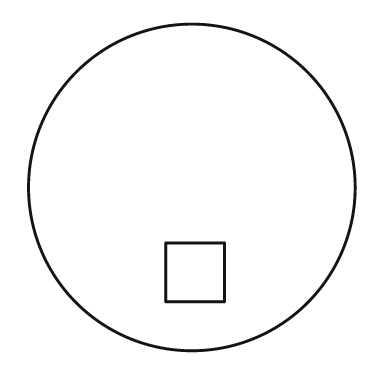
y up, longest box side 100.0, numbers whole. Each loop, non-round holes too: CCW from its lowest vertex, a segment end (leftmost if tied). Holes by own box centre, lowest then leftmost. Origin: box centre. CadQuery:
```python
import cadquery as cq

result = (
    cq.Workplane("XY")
    .moveTo(0.0, 0.0)
    .circle(50.0)
    .moveTo(-8.0, -35.0)
    .lineTo(10.0, -35.0)
    .lineTo(10.0, -17.0)
    .lineTo(-8.0, -17.0)
    .close()
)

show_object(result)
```